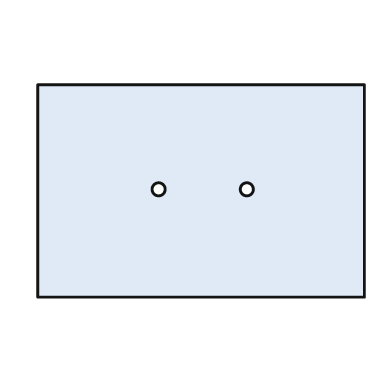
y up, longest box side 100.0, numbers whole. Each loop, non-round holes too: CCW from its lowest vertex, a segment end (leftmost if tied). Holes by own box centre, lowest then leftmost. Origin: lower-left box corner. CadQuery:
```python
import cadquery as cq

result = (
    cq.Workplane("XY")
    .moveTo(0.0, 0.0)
    .lineTo(100.0, 0.0)
    .lineTo(100.0, 65.0)
    .lineTo(0.0, 65.0)
    .close()
    .moveTo(37.0, 33.0)
    .circle(2.0)
    .moveTo(64.0, 33.0)
    .circle(2.0)
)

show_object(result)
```